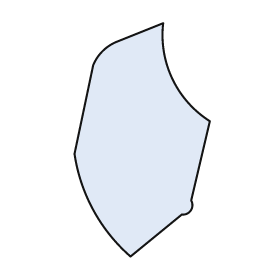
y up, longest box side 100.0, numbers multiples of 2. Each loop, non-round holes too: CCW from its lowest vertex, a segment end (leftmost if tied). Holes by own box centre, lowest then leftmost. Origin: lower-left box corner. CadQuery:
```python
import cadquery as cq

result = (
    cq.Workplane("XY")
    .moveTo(24.0, 0.0)
    .lineTo(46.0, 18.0)
    .threePointArc((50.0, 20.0), (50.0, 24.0))
    .lineTo(58.0, 58.0)
    .threePointArc((42.0, 76.0), (38.0, 100.0))
    .lineTo(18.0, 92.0)
    .threePointArc((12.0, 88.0), (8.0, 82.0))
    .lineTo(0.0, 44.0)
    .threePointArc((8.0, 20.0), (24.0, 0.0))
    .close()
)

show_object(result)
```